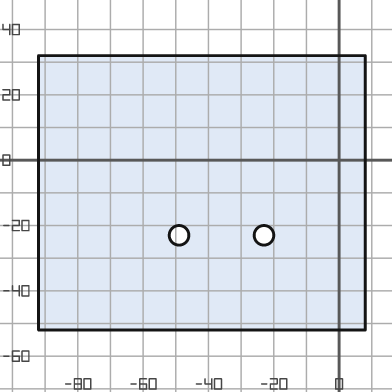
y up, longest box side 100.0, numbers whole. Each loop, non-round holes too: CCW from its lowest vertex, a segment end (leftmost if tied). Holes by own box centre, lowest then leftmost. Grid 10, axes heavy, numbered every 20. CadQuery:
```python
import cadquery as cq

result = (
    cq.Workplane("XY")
    .moveTo(-92.0, -52.0)
    .lineTo(8.0, -52.0)
    .lineTo(8.0, 32.0)
    .lineTo(-92.0, 32.0)
    .close()
    .moveTo(-49.0, -23.0)
    .circle(3.0)
    .moveTo(-23.0, -23.0)
    .circle(3.0)
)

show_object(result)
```